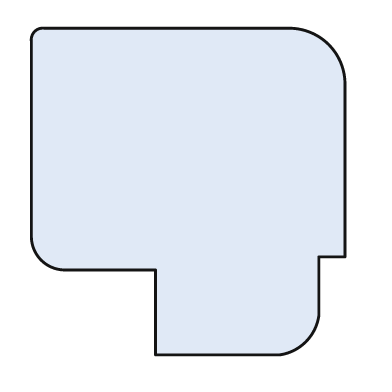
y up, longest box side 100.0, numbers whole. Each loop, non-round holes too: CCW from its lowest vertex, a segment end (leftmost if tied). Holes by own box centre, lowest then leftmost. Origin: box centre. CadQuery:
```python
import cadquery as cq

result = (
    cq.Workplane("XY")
    .moveTo(-10.0, -50.0)
    .lineTo(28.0, -50.0)
    .threePointArc((36.0, -46.0), (40.0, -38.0))
    .lineTo(40.0, -20.0)
    .lineTo(48.0, -20.0)
    .lineTo(48.0, 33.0)
    .threePointArc((43.0, 45.0), (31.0, 50.0))
    .lineTo(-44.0, 50.0)
    .threePointArc((-47.0, 49.0), (-48.0, 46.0))
    .lineTo(-48.0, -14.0)
    .threePointArc((-45.0, -21.0), (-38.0, -24.0))
    .lineTo(-10.0, -24.0)
    .close()
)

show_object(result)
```